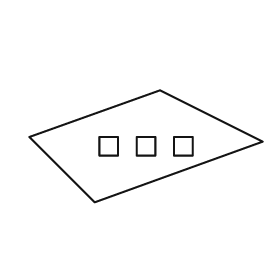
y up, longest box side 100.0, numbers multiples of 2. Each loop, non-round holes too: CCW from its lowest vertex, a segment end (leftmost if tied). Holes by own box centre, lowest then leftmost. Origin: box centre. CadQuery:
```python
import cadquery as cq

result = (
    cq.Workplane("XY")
    .moveTo(-22.0, -24.0)
    .lineTo(50.0, 2.0)
    .lineTo(6.0, 24.0)
    .lineTo(-50.0, 4.0)
    .close()
    .moveTo(-20.0, -4.0)
    .lineTo(-12.0, -4.0)
    .lineTo(-12.0, 4.0)
    .lineTo(-20.0, 4.0)
    .close()
    .moveTo(-4.0, -4.0)
    .lineTo(4.0, -4.0)
    .lineTo(4.0, 4.0)
    .lineTo(-4.0, 4.0)
    .close()
    .moveTo(12.0, -4.0)
    .lineTo(20.0, -4.0)
    .lineTo(20.0, 4.0)
    .lineTo(12.0, 4.0)
    .close()
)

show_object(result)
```